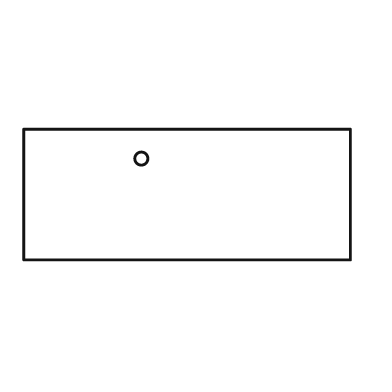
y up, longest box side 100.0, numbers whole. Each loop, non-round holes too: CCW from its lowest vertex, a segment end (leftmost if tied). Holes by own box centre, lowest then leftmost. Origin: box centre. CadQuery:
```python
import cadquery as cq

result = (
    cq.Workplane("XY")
    .moveTo(-50.0, -20.0)
    .lineTo(50.0, -20.0)
    .lineTo(50.0, 20.0)
    .lineTo(-50.0, 20.0)
    .close()
    .moveTo(-14.0, 11.0)
    .circle(2.0)
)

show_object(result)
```